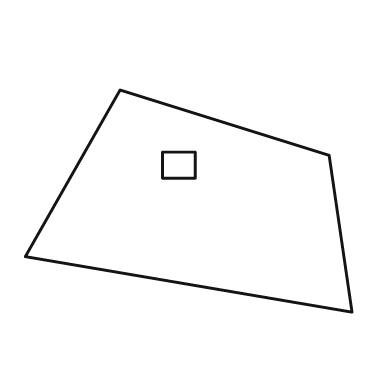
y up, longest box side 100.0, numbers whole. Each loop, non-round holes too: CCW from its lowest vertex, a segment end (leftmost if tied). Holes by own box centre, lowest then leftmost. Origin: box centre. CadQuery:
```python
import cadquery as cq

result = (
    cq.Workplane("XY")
    .moveTo(50.0, -34.0)
    .lineTo(43.0, 14.0)
    .lineTo(-21.0, 34.0)
    .lineTo(-50.0, -17.0)
    .close()
    .moveTo(-8.0, 7.0)
    .lineTo(2.0, 7.0)
    .lineTo(2.0, 15.0)
    .lineTo(-8.0, 15.0)
    .close()
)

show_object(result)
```